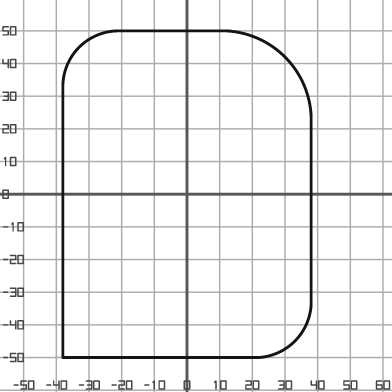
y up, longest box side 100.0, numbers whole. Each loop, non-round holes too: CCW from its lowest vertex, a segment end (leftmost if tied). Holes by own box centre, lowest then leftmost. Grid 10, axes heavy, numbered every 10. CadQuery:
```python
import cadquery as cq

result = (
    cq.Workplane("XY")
    .moveTo(-38.0, -50.0)
    .lineTo(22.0, -50.0)
    .threePointArc((33.0, -45.0), (38.0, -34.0))
    .lineTo(38.0, 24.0)
    .threePointArc((30.0, 42.0), (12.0, 50.0))
    .lineTo(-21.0, 50.0)
    .threePointArc((-33.0, 45.0), (-38.0, 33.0))
    .close()
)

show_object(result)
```